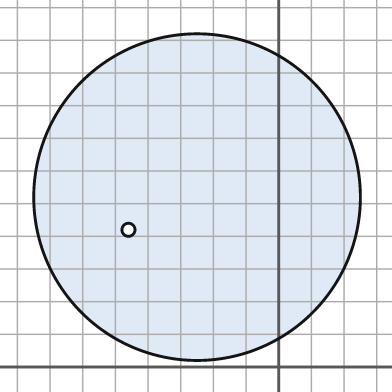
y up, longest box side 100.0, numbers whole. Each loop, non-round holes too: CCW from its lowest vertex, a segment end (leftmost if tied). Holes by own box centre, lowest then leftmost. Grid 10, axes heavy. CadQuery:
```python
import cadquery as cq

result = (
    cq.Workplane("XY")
    .moveTo(-25.0, 52.0)
    .circle(50.0)
    .moveTo(-46.0, 42.0)
    .circle(2.0)
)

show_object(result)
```